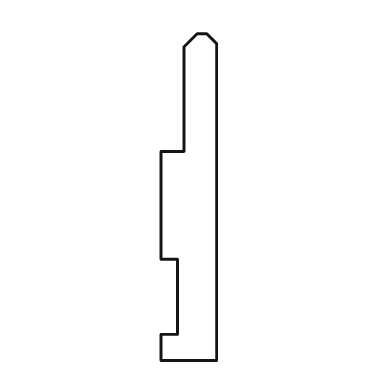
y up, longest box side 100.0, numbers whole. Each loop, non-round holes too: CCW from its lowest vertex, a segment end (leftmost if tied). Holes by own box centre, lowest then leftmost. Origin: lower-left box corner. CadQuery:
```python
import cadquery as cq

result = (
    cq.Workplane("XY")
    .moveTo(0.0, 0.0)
    .lineTo(17.0, 0.0)
    .lineTo(17.0, 97.0)
    .lineTo(14.0, 100.0)
    .lineTo(11.0, 100.0)
    .lineTo(7.0, 96.0)
    .lineTo(7.0, 64.0)
    .lineTo(0.0, 64.0)
    .lineTo(0.0, 31.0)
    .lineTo(5.0, 31.0)
    .lineTo(5.0, 8.0)
    .lineTo(0.0, 8.0)
    .close()
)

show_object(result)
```